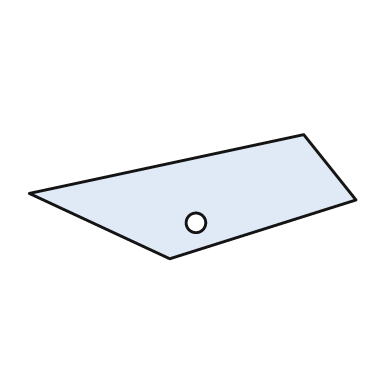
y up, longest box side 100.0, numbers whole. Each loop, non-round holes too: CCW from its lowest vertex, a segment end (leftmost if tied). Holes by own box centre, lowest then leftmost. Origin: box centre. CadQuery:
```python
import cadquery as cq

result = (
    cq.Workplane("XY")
    .moveTo(-7.0, -19.0)
    .lineTo(50.0, -1.0)
    .lineTo(34.0, 19.0)
    .lineTo(-50.0, 1.0)
    .close()
    .moveTo(1.0, -8.0)
    .circle(3.0)
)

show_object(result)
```